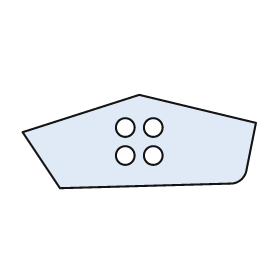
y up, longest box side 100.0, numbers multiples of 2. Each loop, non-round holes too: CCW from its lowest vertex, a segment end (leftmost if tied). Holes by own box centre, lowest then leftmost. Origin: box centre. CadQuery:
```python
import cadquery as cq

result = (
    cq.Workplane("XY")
    .moveTo(-34.0, -20.0)
    .lineTo(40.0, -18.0)
    .threePointArc((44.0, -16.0), (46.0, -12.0))
    .lineTo(50.0, 8.0)
    .lineTo(0.0, 20.0)
    .lineTo(-50.0, 4.0)
    .close()
    .moveTo(-6.0, -6.0)
    .circle(4.0)
    .moveTo(6.0, -6.0)
    .circle(4.0)
    .moveTo(-6.0, 6.0)
    .circle(4.0)
    .moveTo(6.0, 6.0)
    .circle(4.0)
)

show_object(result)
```